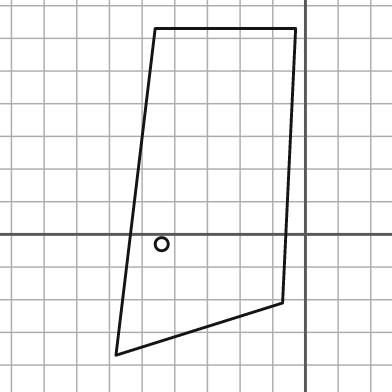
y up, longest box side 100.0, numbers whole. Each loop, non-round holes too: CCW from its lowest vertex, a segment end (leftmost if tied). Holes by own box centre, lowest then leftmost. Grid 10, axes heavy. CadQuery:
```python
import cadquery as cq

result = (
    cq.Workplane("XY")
    .moveTo(-58.0, -37.0)
    .lineTo(-7.0, -21.0)
    .lineTo(-3.0, 63.0)
    .lineTo(-46.0, 63.0)
    .close()
    .moveTo(-44.0, -3.0)
    .circle(2.0)
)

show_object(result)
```